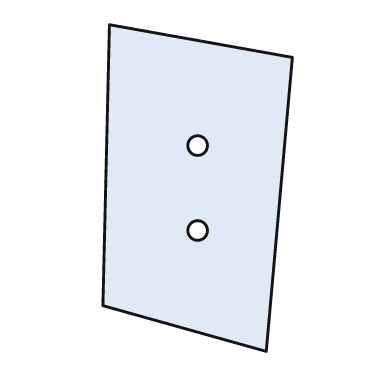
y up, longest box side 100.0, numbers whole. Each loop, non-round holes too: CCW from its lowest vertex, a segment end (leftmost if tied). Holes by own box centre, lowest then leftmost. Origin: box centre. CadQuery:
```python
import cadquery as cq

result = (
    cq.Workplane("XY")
    .moveTo(21.0, -50.0)
    .lineTo(29.0, 40.0)
    .lineTo(-27.0, 50.0)
    .lineTo(-29.0, -36.0)
    .close()
    .moveTo(0.0, -13.0)
    .circle(3.0)
    .moveTo(0.0, 13.0)
    .circle(3.0)
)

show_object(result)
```